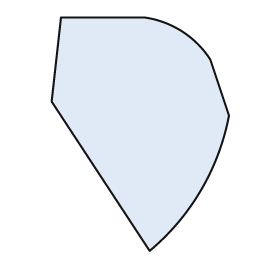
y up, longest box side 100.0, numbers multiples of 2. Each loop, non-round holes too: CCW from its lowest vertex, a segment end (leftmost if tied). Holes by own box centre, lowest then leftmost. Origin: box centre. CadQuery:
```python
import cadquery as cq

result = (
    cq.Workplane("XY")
    .moveTo(4.0, -50.0)
    .threePointArc((26.0, -24.0), (38.0, 8.0))
    .lineTo(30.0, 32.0)
    .threePointArc((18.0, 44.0), (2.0, 50.0))
    .lineTo(-34.0, 50.0)
    .lineTo(-38.0, 14.0)
    .close()
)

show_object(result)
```